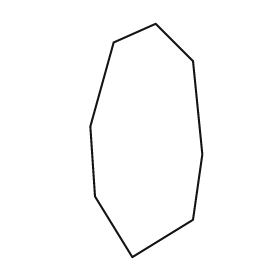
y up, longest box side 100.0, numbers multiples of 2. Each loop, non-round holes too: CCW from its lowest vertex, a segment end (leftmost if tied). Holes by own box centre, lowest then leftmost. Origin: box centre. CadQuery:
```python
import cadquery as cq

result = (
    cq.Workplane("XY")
    .moveTo(-6.0, -50.0)
    .lineTo(20.0, -34.0)
    .lineTo(24.0, -6.0)
    .lineTo(20.0, 34.0)
    .lineTo(4.0, 50.0)
    .lineTo(-14.0, 42.0)
    .lineTo(-24.0, 6.0)
    .lineTo(-22.0, -24.0)
    .close()
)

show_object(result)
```